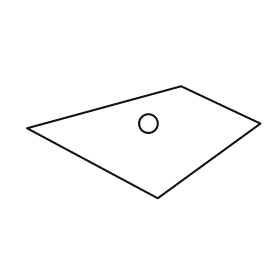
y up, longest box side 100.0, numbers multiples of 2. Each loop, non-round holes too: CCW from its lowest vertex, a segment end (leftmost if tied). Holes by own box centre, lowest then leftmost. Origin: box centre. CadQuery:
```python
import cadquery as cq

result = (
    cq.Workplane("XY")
    .moveTo(6.0, -24.0)
    .lineTo(50.0, 8.0)
    .lineTo(16.0, 24.0)
    .lineTo(-50.0, 6.0)
    .close()
    .moveTo(2.0, 8.0)
    .circle(4.0)
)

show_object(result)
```